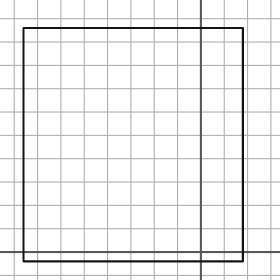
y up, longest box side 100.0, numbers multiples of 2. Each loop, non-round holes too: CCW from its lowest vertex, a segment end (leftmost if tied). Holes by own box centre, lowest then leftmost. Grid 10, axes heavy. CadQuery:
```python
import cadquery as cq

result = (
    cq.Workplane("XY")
    .moveTo(-76.0, -4.0)
    .lineTo(18.0, -4.0)
    .lineTo(18.0, 96.0)
    .lineTo(-76.0, 96.0)
    .close()
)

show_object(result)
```